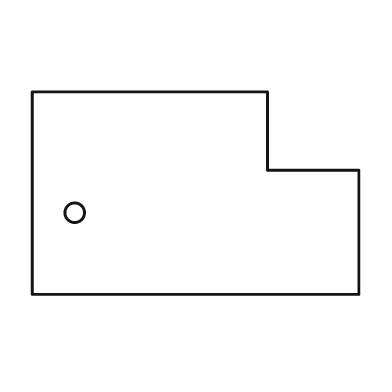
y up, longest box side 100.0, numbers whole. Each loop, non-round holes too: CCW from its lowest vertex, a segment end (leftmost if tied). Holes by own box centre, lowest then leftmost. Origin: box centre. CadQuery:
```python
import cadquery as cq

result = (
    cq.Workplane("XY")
    .moveTo(-50.0, -31.0)
    .lineTo(50.0, -31.0)
    .lineTo(50.0, 7.0)
    .lineTo(22.0, 7.0)
    .lineTo(22.0, 31.0)
    .lineTo(-50.0, 31.0)
    .close()
    .moveTo(-37.0, -6.0)
    .circle(3.0)
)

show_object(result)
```